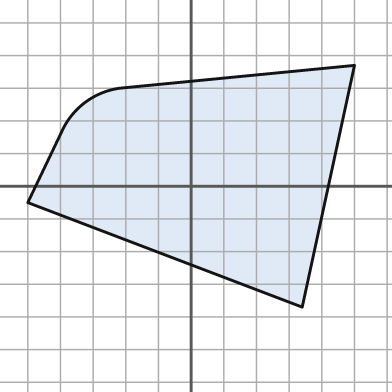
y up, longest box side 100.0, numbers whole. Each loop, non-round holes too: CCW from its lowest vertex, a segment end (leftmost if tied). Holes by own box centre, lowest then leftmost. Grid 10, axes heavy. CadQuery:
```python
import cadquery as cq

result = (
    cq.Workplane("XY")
    .moveTo(34.0, -37.0)
    .lineTo(50.0, 37.0)
    .lineTo(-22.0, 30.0)
    .threePointArc((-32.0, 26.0), (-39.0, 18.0))
    .lineTo(-50.0, -5.0)
    .close()
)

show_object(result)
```